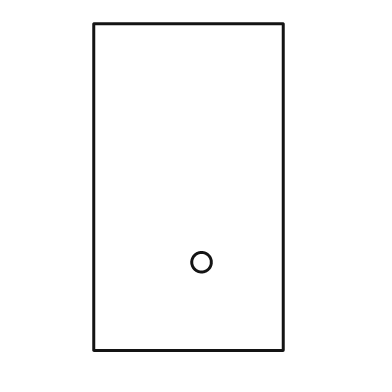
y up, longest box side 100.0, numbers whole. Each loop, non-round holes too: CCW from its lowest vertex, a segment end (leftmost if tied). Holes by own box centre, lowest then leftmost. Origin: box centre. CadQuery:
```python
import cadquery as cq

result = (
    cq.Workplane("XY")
    .moveTo(-29.0, -50.0)
    .lineTo(29.0, -50.0)
    .lineTo(29.0, 50.0)
    .lineTo(-29.0, 50.0)
    .close()
    .moveTo(4.0, -23.0)
    .circle(3.0)
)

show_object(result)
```